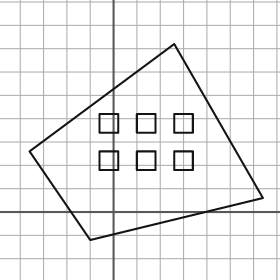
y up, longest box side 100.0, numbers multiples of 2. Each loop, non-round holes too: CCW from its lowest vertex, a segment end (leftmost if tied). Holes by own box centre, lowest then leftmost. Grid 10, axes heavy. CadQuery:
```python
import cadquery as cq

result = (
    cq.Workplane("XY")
    .moveTo(-10.0, -12.0)
    .lineTo(64.0, 6.0)
    .lineTo(26.0, 72.0)
    .lineTo(-36.0, 26.0)
    .close()
    .moveTo(-6.0, 18.0)
    .lineTo(2.0, 18.0)
    .lineTo(2.0, 26.0)
    .lineTo(-6.0, 26.0)
    .close()
    .moveTo(10.0, 18.0)
    .lineTo(18.0, 18.0)
    .lineTo(18.0, 26.0)
    .lineTo(10.0, 26.0)
    .close()
    .moveTo(26.0, 18.0)
    .lineTo(34.0, 18.0)
    .lineTo(34.0, 26.0)
    .lineTo(26.0, 26.0)
    .close()
    .moveTo(-6.0, 34.0)
    .lineTo(2.0, 34.0)
    .lineTo(2.0, 42.0)
    .lineTo(-6.0, 42.0)
    .close()
    .moveTo(10.0, 34.0)
    .lineTo(18.0, 34.0)
    .lineTo(18.0, 42.0)
    .lineTo(10.0, 42.0)
    .close()
    .moveTo(26.0, 34.0)
    .lineTo(34.0, 34.0)
    .lineTo(34.0, 42.0)
    .lineTo(26.0, 42.0)
    .close()
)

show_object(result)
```